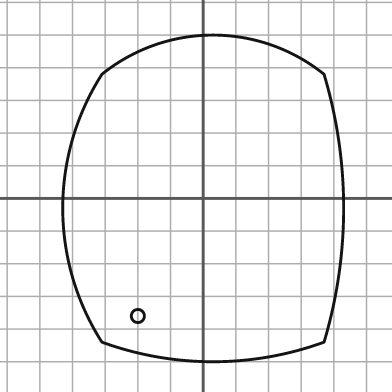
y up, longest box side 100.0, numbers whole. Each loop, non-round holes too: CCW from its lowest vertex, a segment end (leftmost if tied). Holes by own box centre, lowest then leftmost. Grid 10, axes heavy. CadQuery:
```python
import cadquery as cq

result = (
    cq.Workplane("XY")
    .moveTo(-31.0, -44.0)
    .threePointArc((3.0, -50.0), (37.0, -44.0))
    .threePointArc((43.0, -3.0), (37.0, 38.0))
    .threePointArc((3.0, 50.0), (-31.0, 38.0))
    .threePointArc((-43.0, -3.0), (-31.0, -44.0))
    .close()
    .moveTo(-20.0, -36.0)
    .circle(2.0)
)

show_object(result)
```